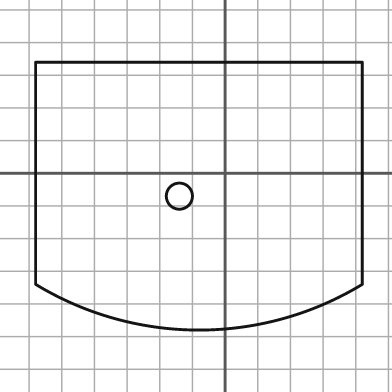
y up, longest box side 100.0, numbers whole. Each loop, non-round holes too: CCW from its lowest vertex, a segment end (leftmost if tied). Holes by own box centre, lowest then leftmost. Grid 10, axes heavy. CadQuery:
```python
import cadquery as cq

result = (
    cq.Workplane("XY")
    .moveTo(-58.0, -34.0)
    .threePointArc((-8.0, -48.0), (42.0, -34.0))
    .lineTo(42.0, 34.0)
    .lineTo(-58.0, 34.0)
    .close()
    .moveTo(-14.0, -7.0)
    .circle(4.0)
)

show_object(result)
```